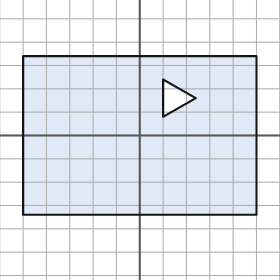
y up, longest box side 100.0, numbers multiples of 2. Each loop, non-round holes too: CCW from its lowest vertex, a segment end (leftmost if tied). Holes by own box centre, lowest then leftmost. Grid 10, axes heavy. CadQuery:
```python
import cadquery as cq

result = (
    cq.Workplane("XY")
    .moveTo(-50.0, -34.0)
    .lineTo(50.0, -34.0)
    .lineTo(50.0, 34.0)
    .lineTo(-50.0, 34.0)
    .close()
    .moveTo(10.0, 8.0)
    .lineTo(24.0, 16.0)
    .lineTo(10.0, 24.0)
    .close()
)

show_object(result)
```